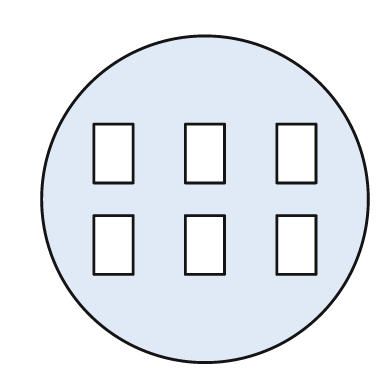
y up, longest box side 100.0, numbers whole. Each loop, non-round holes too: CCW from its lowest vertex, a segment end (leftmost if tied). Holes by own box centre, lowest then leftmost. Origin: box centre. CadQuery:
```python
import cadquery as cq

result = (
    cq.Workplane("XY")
    .moveTo(0.0, 0.0)
    .circle(50.0)
    .moveTo(-34.0, -23.0)
    .lineTo(-22.0, -23.0)
    .lineTo(-22.0, -5.0)
    .lineTo(-34.0, -5.0)
    .close()
    .moveTo(-6.0, -23.0)
    .lineTo(6.0, -23.0)
    .lineTo(6.0, -5.0)
    .lineTo(-6.0, -5.0)
    .close()
    .moveTo(22.0, -23.0)
    .lineTo(34.0, -23.0)
    .lineTo(34.0, -5.0)
    .lineTo(22.0, -5.0)
    .close()
    .moveTo(-34.0, 5.0)
    .lineTo(-22.0, 5.0)
    .lineTo(-22.0, 23.0)
    .lineTo(-34.0, 23.0)
    .close()
    .moveTo(-6.0, 5.0)
    .lineTo(6.0, 5.0)
    .lineTo(6.0, 23.0)
    .lineTo(-6.0, 23.0)
    .close()
    .moveTo(22.0, 5.0)
    .lineTo(34.0, 5.0)
    .lineTo(34.0, 23.0)
    .lineTo(22.0, 23.0)
    .close()
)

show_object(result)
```